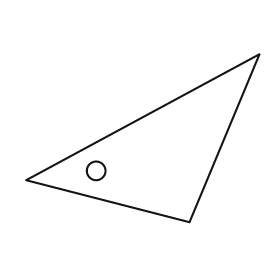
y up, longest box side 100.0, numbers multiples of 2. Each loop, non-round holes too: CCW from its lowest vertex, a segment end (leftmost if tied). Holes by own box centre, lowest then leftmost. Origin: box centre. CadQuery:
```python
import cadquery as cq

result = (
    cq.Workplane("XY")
    .moveTo(20.0, -36.0)
    .lineTo(50.0, 36.0)
    .lineTo(-50.0, -18.0)
    .close()
    .moveTo(-20.0, -14.0)
    .circle(4.0)
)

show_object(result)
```